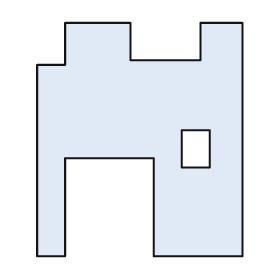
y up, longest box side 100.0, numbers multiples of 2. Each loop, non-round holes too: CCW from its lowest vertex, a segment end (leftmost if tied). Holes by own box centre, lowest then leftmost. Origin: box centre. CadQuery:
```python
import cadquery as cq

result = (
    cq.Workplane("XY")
    .moveTo(-44.0, -50.0)
    .lineTo(-32.0, -50.0)
    .lineTo(-32.0, -8.0)
    .lineTo(6.0, -8.0)
    .lineTo(6.0, -50.0)
    .lineTo(44.0, -50.0)
    .lineTo(44.0, 50.0)
    .lineTo(26.0, 50.0)
    .lineTo(26.0, 34.0)
    .lineTo(-4.0, 34.0)
    .lineTo(-4.0, 50.0)
    .lineTo(-32.0, 50.0)
    .lineTo(-32.0, 32.0)
    .lineTo(-44.0, 32.0)
    .close()
    .moveTo(18.0, -12.0)
    .lineTo(30.0, -12.0)
    .lineTo(30.0, 4.0)
    .lineTo(18.0, 4.0)
    .close()
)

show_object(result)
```